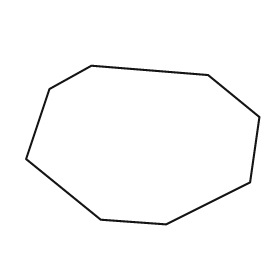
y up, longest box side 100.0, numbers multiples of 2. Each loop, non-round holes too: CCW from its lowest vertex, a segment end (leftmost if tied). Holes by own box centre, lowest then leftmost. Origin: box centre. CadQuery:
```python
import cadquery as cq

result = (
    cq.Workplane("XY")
    .moveTo(10.0, -34.0)
    .lineTo(46.0, -16.0)
    .lineTo(50.0, 12.0)
    .lineTo(28.0, 30.0)
    .lineTo(-22.0, 34.0)
    .lineTo(-40.0, 24.0)
    .lineTo(-50.0, -6.0)
    .lineTo(-18.0, -32.0)
    .close()
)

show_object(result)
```